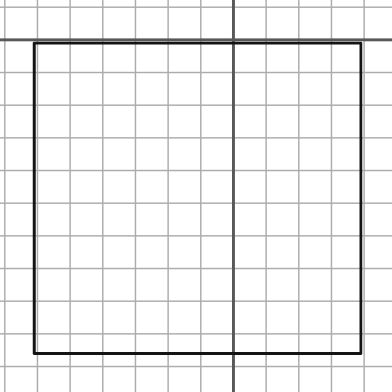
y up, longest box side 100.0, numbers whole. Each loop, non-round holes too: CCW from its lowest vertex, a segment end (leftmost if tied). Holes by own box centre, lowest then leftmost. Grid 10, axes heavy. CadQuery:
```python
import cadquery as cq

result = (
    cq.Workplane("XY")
    .moveTo(-61.0, -96.0)
    .lineTo(39.0, -96.0)
    .lineTo(39.0, -1.0)
    .lineTo(-61.0, -1.0)
    .close()
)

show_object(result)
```